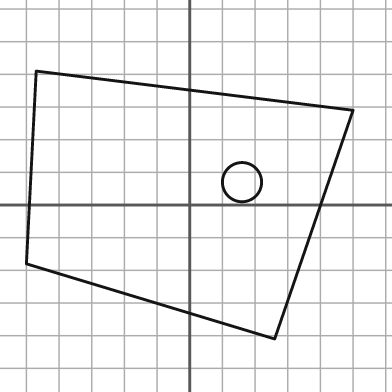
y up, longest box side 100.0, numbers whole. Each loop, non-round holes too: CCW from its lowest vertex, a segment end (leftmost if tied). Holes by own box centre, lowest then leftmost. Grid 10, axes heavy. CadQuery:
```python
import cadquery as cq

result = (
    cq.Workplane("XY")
    .moveTo(26.0, -41.0)
    .lineTo(50.0, 29.0)
    .lineTo(-47.0, 41.0)
    .lineTo(-50.0, -18.0)
    .close()
    .moveTo(16.0, 7.0)
    .circle(6.0)
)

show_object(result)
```